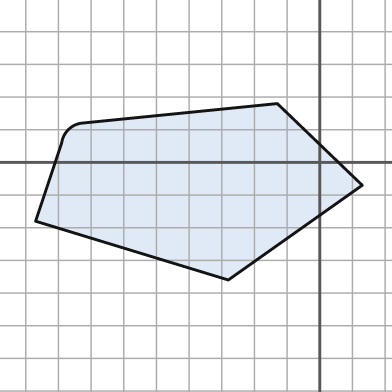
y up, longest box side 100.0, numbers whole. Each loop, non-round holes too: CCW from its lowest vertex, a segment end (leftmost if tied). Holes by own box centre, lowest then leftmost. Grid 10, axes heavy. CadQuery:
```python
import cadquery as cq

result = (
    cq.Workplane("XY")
    .moveTo(-28.0, -36.0)
    .lineTo(13.0, -7.0)
    .lineTo(-13.0, 18.0)
    .lineTo(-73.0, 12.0)
    .threePointArc((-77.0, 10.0), (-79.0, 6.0))
    .lineTo(-87.0, -18.0)
    .close()
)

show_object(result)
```